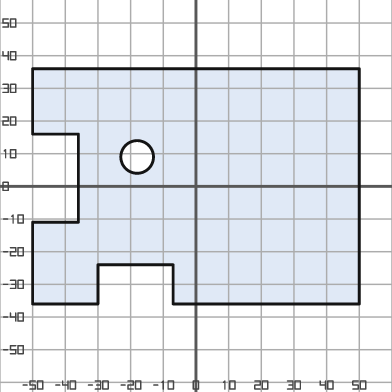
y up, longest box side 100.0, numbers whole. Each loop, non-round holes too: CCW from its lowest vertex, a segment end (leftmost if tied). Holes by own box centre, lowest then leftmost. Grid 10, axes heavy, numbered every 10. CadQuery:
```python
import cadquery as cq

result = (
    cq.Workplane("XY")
    .moveTo(-50.0, -36.0)
    .lineTo(-30.0, -36.0)
    .lineTo(-30.0, -24.0)
    .lineTo(-7.0, -24.0)
    .lineTo(-7.0, -36.0)
    .lineTo(50.0, -36.0)
    .lineTo(50.0, 36.0)
    .lineTo(-50.0, 36.0)
    .lineTo(-50.0, 16.0)
    .lineTo(-36.0, 16.0)
    .lineTo(-36.0, -11.0)
    .lineTo(-50.0, -11.0)
    .close()
    .moveTo(-18.0, 9.0)
    .circle(5.0)
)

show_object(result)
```